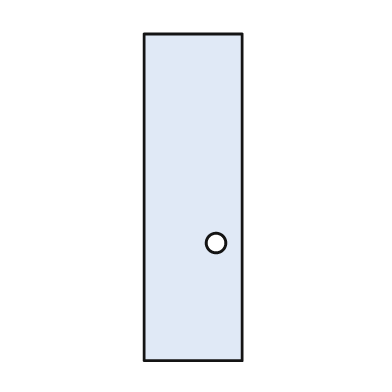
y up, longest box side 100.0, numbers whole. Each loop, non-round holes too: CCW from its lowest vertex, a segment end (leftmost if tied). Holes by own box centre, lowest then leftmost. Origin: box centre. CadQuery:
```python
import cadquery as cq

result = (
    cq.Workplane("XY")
    .moveTo(-15.0, -50.0)
    .lineTo(15.0, -50.0)
    .lineTo(15.0, 50.0)
    .lineTo(-15.0, 50.0)
    .close()
    .moveTo(7.0, -14.0)
    .circle(3.0)
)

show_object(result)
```